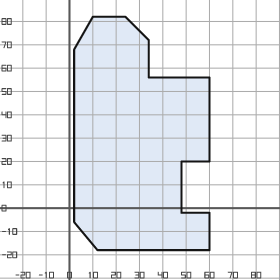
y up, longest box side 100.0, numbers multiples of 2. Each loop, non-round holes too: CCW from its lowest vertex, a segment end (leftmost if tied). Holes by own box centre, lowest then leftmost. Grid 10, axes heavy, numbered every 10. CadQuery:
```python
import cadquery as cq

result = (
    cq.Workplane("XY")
    .moveTo(12.0, -18.0)
    .lineTo(60.0, -18.0)
    .lineTo(60.0, -2.0)
    .lineTo(48.0, -2.0)
    .lineTo(48.0, 20.0)
    .lineTo(60.0, 20.0)
    .lineTo(60.0, 56.0)
    .lineTo(34.0, 56.0)
    .lineTo(34.0, 72.0)
    .lineTo(24.0, 82.0)
    .lineTo(10.0, 82.0)
    .lineTo(2.0, 68.0)
    .lineTo(2.0, -6.0)
    .close()
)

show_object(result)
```